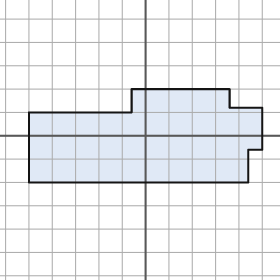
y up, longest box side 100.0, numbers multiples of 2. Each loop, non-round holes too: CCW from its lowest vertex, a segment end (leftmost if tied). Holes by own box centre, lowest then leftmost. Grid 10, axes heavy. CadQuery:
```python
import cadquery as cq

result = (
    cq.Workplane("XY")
    .moveTo(-50.0, -20.0)
    .lineTo(44.0, -20.0)
    .lineTo(44.0, -6.0)
    .lineTo(50.0, -6.0)
    .lineTo(50.0, 12.0)
    .lineTo(36.0, 12.0)
    .lineTo(36.0, 20.0)
    .lineTo(-6.0, 20.0)
    .lineTo(-6.0, 10.0)
    .lineTo(-50.0, 10.0)
    .close()
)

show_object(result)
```